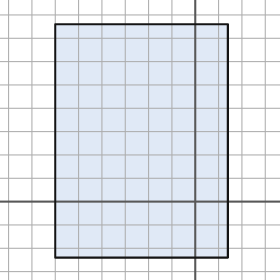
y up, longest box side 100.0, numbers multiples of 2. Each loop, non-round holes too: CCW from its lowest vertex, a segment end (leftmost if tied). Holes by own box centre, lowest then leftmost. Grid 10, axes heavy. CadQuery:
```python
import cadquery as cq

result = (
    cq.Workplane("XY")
    .moveTo(-60.0, -24.0)
    .lineTo(14.0, -24.0)
    .lineTo(14.0, 76.0)
    .lineTo(-60.0, 76.0)
    .close()
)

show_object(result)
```